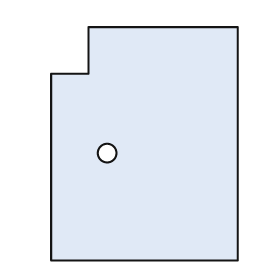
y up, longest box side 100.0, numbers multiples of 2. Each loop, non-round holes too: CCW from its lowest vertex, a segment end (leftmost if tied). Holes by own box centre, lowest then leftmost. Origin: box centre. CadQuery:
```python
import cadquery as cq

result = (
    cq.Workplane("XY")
    .moveTo(-40.0, -50.0)
    .lineTo(40.0, -50.0)
    .lineTo(40.0, 50.0)
    .lineTo(-24.0, 50.0)
    .lineTo(-24.0, 30.0)
    .lineTo(-40.0, 30.0)
    .close()
    .moveTo(-16.0, -4.0)
    .circle(4.0)
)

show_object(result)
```